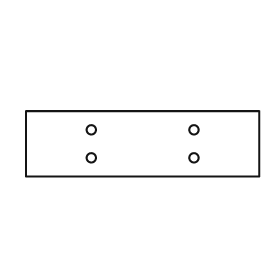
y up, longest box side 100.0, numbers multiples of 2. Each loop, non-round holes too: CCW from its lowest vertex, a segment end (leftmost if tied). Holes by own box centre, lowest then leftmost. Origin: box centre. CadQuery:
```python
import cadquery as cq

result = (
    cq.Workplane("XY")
    .moveTo(-50.0, -14.0)
    .lineTo(50.0, -14.0)
    .lineTo(50.0, 14.0)
    .lineTo(-50.0, 14.0)
    .close()
    .moveTo(-22.0, -6.0)
    .circle(2.0)
    .moveTo(22.0, -6.0)
    .circle(2.0)
    .moveTo(-22.0, 6.0)
    .circle(2.0)
    .moveTo(22.0, 6.0)
    .circle(2.0)
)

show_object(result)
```